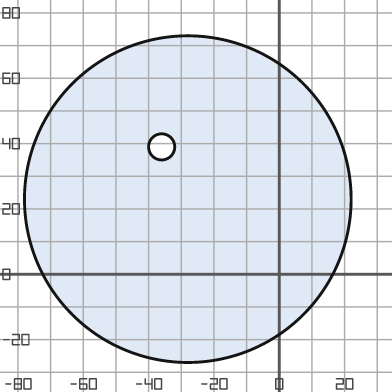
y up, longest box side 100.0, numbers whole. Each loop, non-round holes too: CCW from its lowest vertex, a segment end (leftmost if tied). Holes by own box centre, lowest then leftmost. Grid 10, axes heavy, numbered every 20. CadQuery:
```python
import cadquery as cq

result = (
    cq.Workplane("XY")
    .moveTo(-28.0, 23.0)
    .circle(50.0)
    .moveTo(-36.0, 39.0)
    .circle(4.0)
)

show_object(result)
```